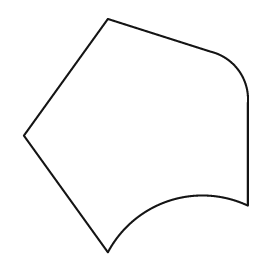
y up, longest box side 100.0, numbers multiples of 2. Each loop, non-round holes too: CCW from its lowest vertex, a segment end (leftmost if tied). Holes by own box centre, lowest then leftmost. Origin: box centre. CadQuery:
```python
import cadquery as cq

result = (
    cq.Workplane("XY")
    .moveTo(-12.0, -50.0)
    .threePointArc((14.0, -28.0), (48.0, -30.0))
    .lineTo(48.0, 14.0)
    .threePointArc((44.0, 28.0), (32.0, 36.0))
    .lineTo(-12.0, 50.0)
    .lineTo(-48.0, 0.0)
    .close()
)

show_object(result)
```